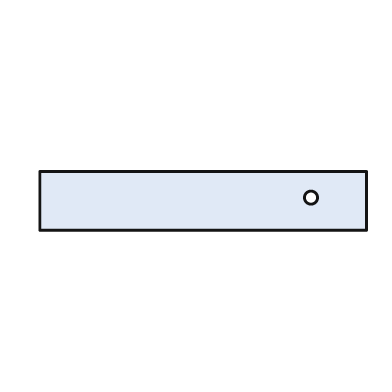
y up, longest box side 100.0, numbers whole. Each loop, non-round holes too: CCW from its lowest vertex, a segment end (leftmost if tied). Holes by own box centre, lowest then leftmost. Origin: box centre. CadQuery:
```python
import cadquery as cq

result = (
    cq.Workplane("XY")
    .moveTo(-50.0, -9.0)
    .lineTo(50.0, -9.0)
    .lineTo(50.0, 9.0)
    .lineTo(-50.0, 9.0)
    .close()
    .moveTo(33.0, 1.0)
    .circle(2.0)
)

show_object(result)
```